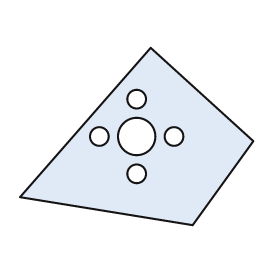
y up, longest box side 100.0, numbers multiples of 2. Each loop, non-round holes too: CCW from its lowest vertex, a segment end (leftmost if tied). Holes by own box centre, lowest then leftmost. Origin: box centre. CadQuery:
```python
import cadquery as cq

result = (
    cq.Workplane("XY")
    .moveTo(24.0, -38.0)
    .lineTo(50.0, -2.0)
    .lineTo(6.0, 38.0)
    .lineTo(-50.0, -26.0)
    .close()
    .moveTo(0.0, -16.0)
    .circle(4.0)
    .moveTo(-16.0, 0.0)
    .circle(4.0)
    .moveTo(0.0, 0.0)
    .circle(8.0)
    .moveTo(16.0, 0.0)
    .circle(4.0)
    .moveTo(0.0, 16.0)
    .circle(4.0)
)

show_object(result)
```